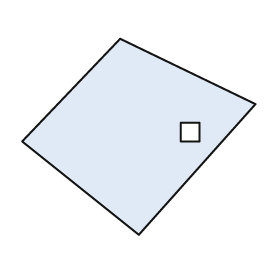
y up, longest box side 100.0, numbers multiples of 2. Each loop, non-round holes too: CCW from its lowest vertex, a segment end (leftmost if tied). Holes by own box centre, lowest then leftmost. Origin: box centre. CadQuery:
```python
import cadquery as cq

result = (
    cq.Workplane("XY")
    .moveTo(0.0, -42.0)
    .lineTo(50.0, 14.0)
    .lineTo(-8.0, 42.0)
    .lineTo(-50.0, -2.0)
    .close()
    .moveTo(18.0, -2.0)
    .lineTo(26.0, -2.0)
    .lineTo(26.0, 6.0)
    .lineTo(18.0, 6.0)
    .close()
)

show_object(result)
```